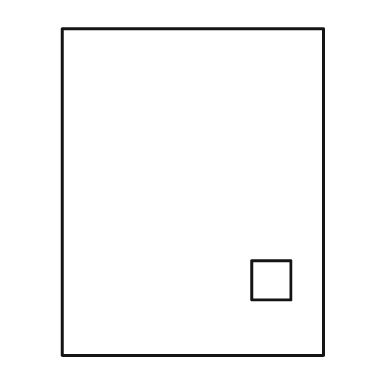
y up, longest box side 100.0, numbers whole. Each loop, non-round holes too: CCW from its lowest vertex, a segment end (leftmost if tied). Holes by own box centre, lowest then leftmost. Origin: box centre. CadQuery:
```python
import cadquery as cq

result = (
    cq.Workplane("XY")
    .moveTo(-40.0, -50.0)
    .lineTo(40.0, -50.0)
    .lineTo(40.0, 50.0)
    .lineTo(-40.0, 50.0)
    .close()
    .moveTo(18.0, -33.0)
    .lineTo(30.0, -33.0)
    .lineTo(30.0, -21.0)
    .lineTo(18.0, -21.0)
    .close()
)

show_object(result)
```